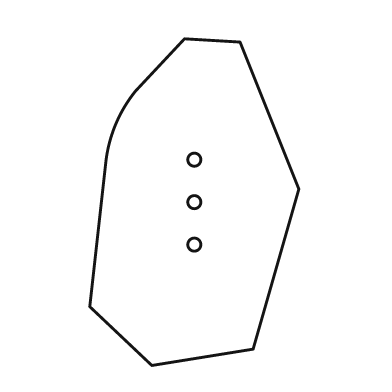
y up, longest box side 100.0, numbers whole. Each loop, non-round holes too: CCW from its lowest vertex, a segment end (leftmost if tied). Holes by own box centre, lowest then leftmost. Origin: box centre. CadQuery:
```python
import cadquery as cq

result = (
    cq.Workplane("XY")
    .moveTo(-13.0, -50.0)
    .lineTo(18.0, -45.0)
    .lineTo(32.0, 4.0)
    .lineTo(14.0, 49.0)
    .lineTo(-3.0, 50.0)
    .lineTo(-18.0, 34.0)
    .threePointArc((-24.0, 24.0), (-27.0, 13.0))
    .lineTo(-32.0, -32.0)
    .close()
    .moveTo(0.0, -13.0)
    .circle(2.0)
    .moveTo(0.0, 0.0)
    .circle(2.0)
    .moveTo(0.0, 13.0)
    .circle(2.0)
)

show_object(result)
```